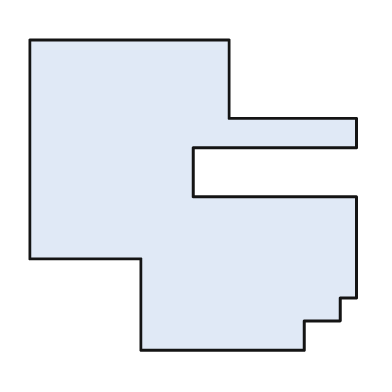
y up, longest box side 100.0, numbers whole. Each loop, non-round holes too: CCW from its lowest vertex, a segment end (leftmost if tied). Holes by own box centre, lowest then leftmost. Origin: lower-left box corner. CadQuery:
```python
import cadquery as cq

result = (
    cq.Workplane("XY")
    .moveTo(34.0, 0.0)
    .lineTo(84.0, 0.0)
    .lineTo(84.0, 9.0)
    .lineTo(95.0, 9.0)
    .lineTo(95.0, 16.0)
    .lineTo(100.0, 16.0)
    .lineTo(100.0, 47.0)
    .lineTo(50.0, 47.0)
    .lineTo(50.0, 62.0)
    .lineTo(100.0, 62.0)
    .lineTo(100.0, 71.0)
    .lineTo(61.0, 71.0)
    .lineTo(61.0, 95.0)
    .lineTo(0.0, 95.0)
    .lineTo(0.0, 28.0)
    .lineTo(34.0, 28.0)
    .close()
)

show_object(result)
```